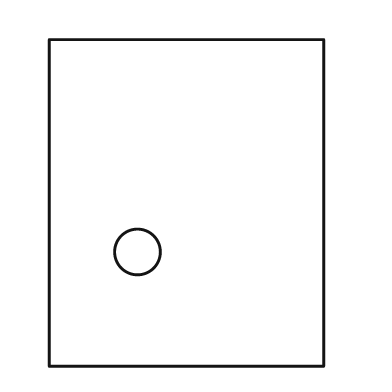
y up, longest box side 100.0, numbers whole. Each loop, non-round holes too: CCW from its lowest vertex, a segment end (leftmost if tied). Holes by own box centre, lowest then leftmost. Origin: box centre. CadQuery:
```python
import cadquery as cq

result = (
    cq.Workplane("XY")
    .moveTo(-42.0, -50.0)
    .lineTo(42.0, -50.0)
    .lineTo(42.0, 50.0)
    .lineTo(-42.0, 50.0)
    .close()
    .moveTo(-15.0, -15.0)
    .circle(7.0)
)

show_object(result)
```